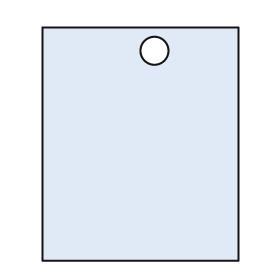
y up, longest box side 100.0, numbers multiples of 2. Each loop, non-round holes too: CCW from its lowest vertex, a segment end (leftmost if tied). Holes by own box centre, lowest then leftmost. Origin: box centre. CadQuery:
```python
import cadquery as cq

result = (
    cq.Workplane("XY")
    .moveTo(-42.0, -50.0)
    .lineTo(42.0, -50.0)
    .lineTo(42.0, 50.0)
    .lineTo(-42.0, 50.0)
    .close()
    .moveTo(6.0, 40.0)
    .circle(6.0)
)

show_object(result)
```